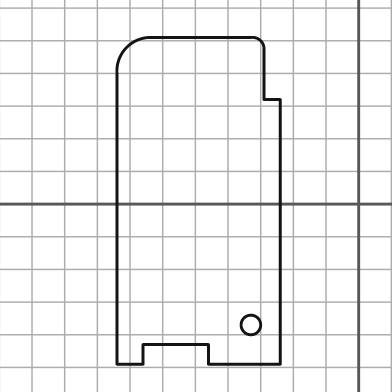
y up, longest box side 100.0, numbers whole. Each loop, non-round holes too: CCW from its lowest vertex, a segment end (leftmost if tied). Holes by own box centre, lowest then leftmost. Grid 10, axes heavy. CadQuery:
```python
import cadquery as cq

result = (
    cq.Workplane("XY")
    .moveTo(-74.0, -49.0)
    .lineTo(-66.0, -49.0)
    .lineTo(-66.0, -43.0)
    .lineTo(-46.0, -43.0)
    .lineTo(-46.0, -49.0)
    .lineTo(-24.0, -49.0)
    .lineTo(-24.0, 32.0)
    .lineTo(-29.0, 32.0)
    .lineTo(-29.0, 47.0)
    .threePointArc((-30.0, 50.0), (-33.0, 51.0))
    .lineTo(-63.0, 51.0)
    .threePointArc((-71.0, 48.0), (-74.0, 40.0))
    .close()
    .moveTo(-33.0, -37.0)
    .circle(3.0)
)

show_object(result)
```